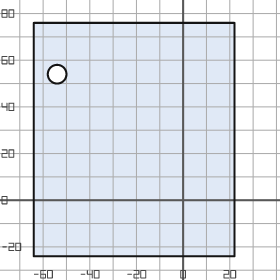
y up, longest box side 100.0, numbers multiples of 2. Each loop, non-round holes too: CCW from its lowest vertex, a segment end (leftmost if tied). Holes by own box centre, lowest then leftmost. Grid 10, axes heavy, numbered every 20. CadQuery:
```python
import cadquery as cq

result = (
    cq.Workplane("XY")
    .moveTo(-64.0, -24.0)
    .lineTo(22.0, -24.0)
    .lineTo(22.0, 76.0)
    .lineTo(-64.0, 76.0)
    .close()
    .moveTo(-54.0, 54.0)
    .circle(4.0)
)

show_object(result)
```